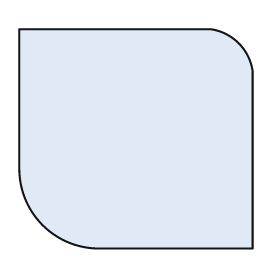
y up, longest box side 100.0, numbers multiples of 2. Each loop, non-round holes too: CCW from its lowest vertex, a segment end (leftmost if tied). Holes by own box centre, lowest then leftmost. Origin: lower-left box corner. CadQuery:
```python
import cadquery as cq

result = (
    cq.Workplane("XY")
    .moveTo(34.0, 0.0)
    .lineTo(100.0, 0.0)
    .lineTo(100.0, 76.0)
    .threePointArc((94.0, 88.0), (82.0, 94.0))
    .lineTo(0.0, 94.0)
    .lineTo(0.0, 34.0)
    .threePointArc((10.0, 10.0), (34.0, 0.0))
    .close()
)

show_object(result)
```